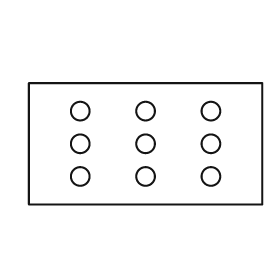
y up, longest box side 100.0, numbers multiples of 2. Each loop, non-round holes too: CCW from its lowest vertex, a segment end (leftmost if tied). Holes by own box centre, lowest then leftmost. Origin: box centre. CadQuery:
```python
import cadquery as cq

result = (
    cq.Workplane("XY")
    .moveTo(-50.0, -26.0)
    .lineTo(50.0, -26.0)
    .lineTo(50.0, 26.0)
    .lineTo(-50.0, 26.0)
    .close()
    .moveTo(-28.0, -14.0)
    .circle(4.0)
    .moveTo(0.0, -14.0)
    .circle(4.0)
    .moveTo(28.0, -14.0)
    .circle(4.0)
    .moveTo(-28.0, 0.0)
    .circle(4.0)
    .moveTo(0.0, 0.0)
    .circle(4.0)
    .moveTo(28.0, 0.0)
    .circle(4.0)
    .moveTo(-28.0, 14.0)
    .circle(4.0)
    .moveTo(0.0, 14.0)
    .circle(4.0)
    .moveTo(28.0, 14.0)
    .circle(4.0)
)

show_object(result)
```